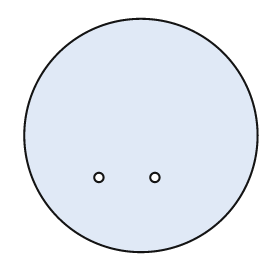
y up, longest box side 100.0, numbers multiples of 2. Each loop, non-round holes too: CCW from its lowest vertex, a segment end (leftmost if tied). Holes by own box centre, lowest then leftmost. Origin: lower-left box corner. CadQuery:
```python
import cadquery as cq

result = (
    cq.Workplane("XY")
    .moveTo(50.0, 50.0)
    .circle(50.0)
    .moveTo(32.0, 32.0)
    .circle(2.0)
    .moveTo(56.0, 32.0)
    .circle(2.0)
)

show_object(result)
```